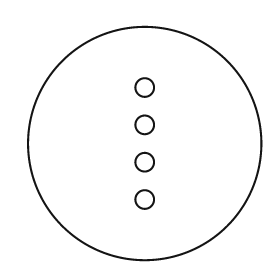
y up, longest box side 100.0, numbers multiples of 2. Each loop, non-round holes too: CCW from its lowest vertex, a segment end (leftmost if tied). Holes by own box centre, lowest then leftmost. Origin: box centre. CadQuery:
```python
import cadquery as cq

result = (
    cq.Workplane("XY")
    .moveTo(0.0, 0.0)
    .circle(50.0)
    .moveTo(0.0, -24.0)
    .circle(4.0)
    .moveTo(0.0, -8.0)
    .circle(4.0)
    .moveTo(0.0, 8.0)
    .circle(4.0)
    .moveTo(0.0, 24.0)
    .circle(4.0)
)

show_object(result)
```